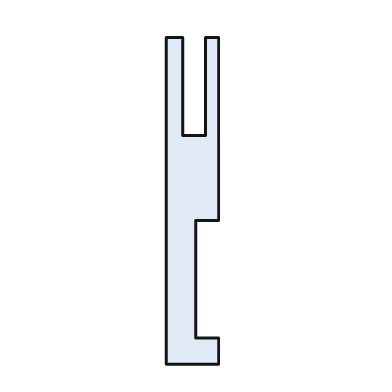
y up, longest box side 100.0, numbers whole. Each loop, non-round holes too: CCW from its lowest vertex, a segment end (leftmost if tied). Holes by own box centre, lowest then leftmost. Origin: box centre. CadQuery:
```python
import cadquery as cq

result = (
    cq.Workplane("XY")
    .moveTo(-8.0, -50.0)
    .lineTo(8.0, -50.0)
    .lineTo(8.0, -42.0)
    .lineTo(1.0, -42.0)
    .lineTo(1.0, -6.0)
    .lineTo(8.0, -6.0)
    .lineTo(8.0, 50.0)
    .lineTo(4.0, 50.0)
    .lineTo(4.0, 20.0)
    .lineTo(-3.0, 20.0)
    .lineTo(-3.0, 50.0)
    .lineTo(-8.0, 50.0)
    .close()
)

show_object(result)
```